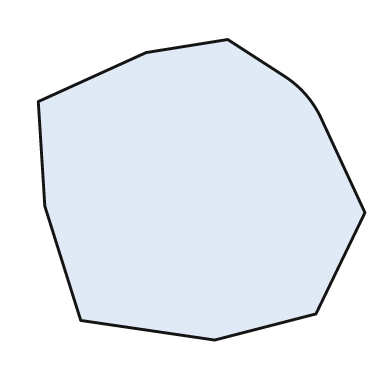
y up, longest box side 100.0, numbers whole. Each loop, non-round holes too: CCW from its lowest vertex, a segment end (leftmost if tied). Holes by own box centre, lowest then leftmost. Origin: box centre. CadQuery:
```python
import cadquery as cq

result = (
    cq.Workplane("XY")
    .moveTo(4.0, -46.0)
    .lineTo(35.0, -38.0)
    .lineTo(50.0, -7.0)
    .lineTo(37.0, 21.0)
    .threePointArc((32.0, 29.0), (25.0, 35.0))
    .lineTo(8.0, 46.0)
    .lineTo(-17.0, 42.0)
    .lineTo(-50.0, 27.0)
    .lineTo(-48.0, -5.0)
    .lineTo(-37.0, -40.0)
    .close()
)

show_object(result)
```